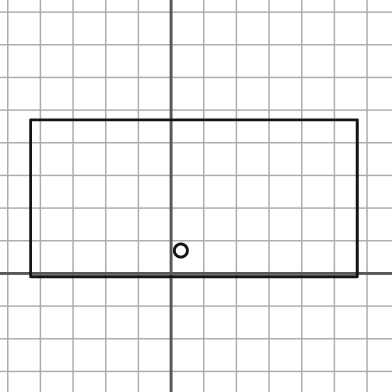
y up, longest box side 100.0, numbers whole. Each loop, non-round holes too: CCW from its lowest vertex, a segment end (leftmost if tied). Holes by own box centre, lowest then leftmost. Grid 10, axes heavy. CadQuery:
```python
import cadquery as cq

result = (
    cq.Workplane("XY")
    .moveTo(-43.0, -1.0)
    .lineTo(57.0, -1.0)
    .lineTo(57.0, 47.0)
    .lineTo(-43.0, 47.0)
    .close()
    .moveTo(3.0, 7.0)
    .circle(2.0)
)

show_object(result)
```